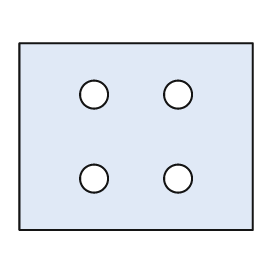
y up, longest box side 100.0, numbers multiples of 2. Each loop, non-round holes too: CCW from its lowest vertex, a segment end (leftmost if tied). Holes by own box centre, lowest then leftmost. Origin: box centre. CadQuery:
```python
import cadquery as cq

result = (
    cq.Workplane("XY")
    .moveTo(-50.0, -40.0)
    .lineTo(50.0, -40.0)
    .lineTo(50.0, 40.0)
    .lineTo(-50.0, 40.0)
    .close()
    .moveTo(-18.0, -18.0)
    .circle(6.0)
    .moveTo(18.0, -18.0)
    .circle(6.0)
    .moveTo(-18.0, 18.0)
    .circle(6.0)
    .moveTo(18.0, 18.0)
    .circle(6.0)
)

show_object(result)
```